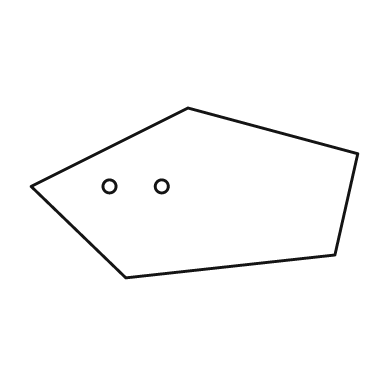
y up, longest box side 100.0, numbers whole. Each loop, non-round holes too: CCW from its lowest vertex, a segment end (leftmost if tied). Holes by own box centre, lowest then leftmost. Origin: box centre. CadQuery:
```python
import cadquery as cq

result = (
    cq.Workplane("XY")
    .moveTo(-21.0, -26.0)
    .lineTo(43.0, -19.0)
    .lineTo(50.0, 12.0)
    .lineTo(-2.0, 26.0)
    .lineTo(-50.0, 2.0)
    .close()
    .moveTo(-26.0, 2.0)
    .circle(2.0)
    .moveTo(-10.0, 2.0)
    .circle(2.0)
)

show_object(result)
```